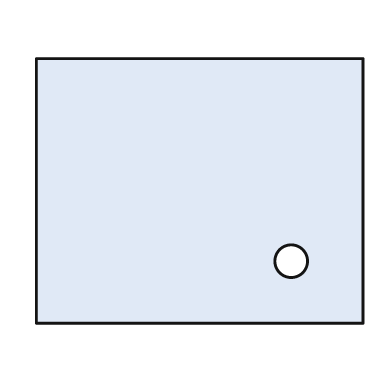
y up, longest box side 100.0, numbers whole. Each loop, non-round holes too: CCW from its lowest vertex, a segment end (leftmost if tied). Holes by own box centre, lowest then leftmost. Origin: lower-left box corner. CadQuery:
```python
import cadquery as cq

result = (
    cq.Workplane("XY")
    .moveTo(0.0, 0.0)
    .lineTo(100.0, 0.0)
    .lineTo(100.0, 81.0)
    .lineTo(0.0, 81.0)
    .close()
    .moveTo(78.0, 19.0)
    .circle(5.0)
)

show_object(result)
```